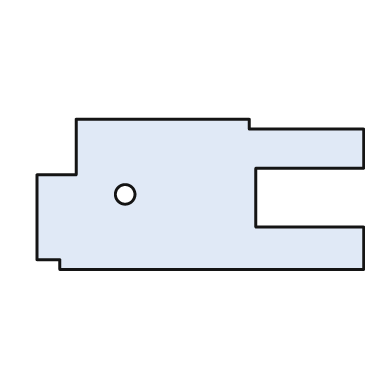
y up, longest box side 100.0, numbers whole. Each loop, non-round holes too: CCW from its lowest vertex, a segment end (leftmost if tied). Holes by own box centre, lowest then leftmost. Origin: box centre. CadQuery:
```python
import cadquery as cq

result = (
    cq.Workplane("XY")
    .moveTo(-43.0, -23.0)
    .lineTo(50.0, -23.0)
    .lineTo(50.0, -10.0)
    .lineTo(17.0, -10.0)
    .lineTo(17.0, 8.0)
    .lineTo(50.0, 8.0)
    .lineTo(50.0, 20.0)
    .lineTo(15.0, 20.0)
    .lineTo(15.0, 23.0)
    .lineTo(-38.0, 23.0)
    .lineTo(-38.0, 6.0)
    .lineTo(-50.0, 6.0)
    .lineTo(-50.0, -20.0)
    .lineTo(-43.0, -20.0)
    .close()
    .moveTo(-23.0, 0.0)
    .circle(3.0)
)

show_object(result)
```